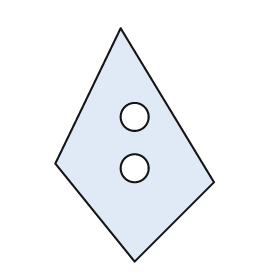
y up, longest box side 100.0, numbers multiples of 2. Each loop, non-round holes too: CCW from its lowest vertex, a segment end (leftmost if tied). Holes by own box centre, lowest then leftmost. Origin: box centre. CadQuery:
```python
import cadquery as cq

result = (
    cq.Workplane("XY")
    .moveTo(0.0, -50.0)
    .lineTo(34.0, -16.0)
    .lineTo(-6.0, 50.0)
    .lineTo(-34.0, -8.0)
    .close()
    .moveTo(0.0, -10.0)
    .circle(6.0)
    .moveTo(0.0, 12.0)
    .circle(6.0)
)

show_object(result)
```